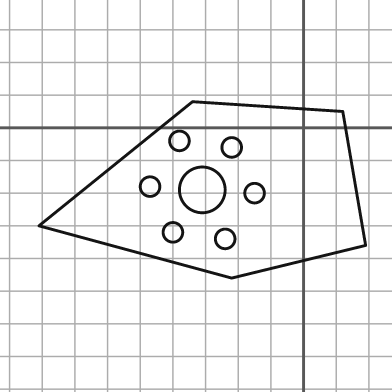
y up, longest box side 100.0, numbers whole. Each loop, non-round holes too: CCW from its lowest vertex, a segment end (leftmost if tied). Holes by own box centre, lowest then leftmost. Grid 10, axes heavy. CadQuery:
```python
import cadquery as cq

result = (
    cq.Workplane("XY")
    .moveTo(-22.0, -46.0)
    .lineTo(19.0, -36.0)
    .lineTo(12.0, 5.0)
    .lineTo(-34.0, 8.0)
    .lineTo(-81.0, -30.0)
    .close()
    .moveTo(-24.0, -34.0)
    .circle(3.0)
    .moveTo(-40.0, -32.0)
    .circle(3.0)
    .moveTo(-15.0, -20.0)
    .circle(3.0)
    .moveTo(-31.0, -19.0)
    .circle(7.0)
    .moveTo(-47.0, -18.0)
    .circle(3.0)
    .moveTo(-22.0, -6.0)
    .circle(3.0)
    .moveTo(-38.0, -4.0)
    .circle(3.0)
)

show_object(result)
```